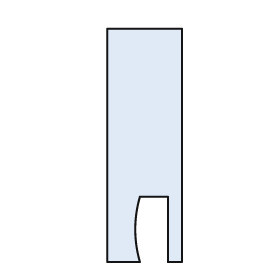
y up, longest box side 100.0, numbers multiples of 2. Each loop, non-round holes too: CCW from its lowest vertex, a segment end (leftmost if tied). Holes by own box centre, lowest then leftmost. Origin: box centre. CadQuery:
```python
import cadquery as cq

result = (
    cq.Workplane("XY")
    .moveTo(-16.0, -50.0)
    .lineTo(-2.0, -50.0)
    .threePointArc((-4.0, -36.0), (-2.0, -22.0))
    .lineTo(10.0, -22.0)
    .lineTo(10.0, -50.0)
    .lineTo(16.0, -50.0)
    .lineTo(16.0, 50.0)
    .lineTo(-16.0, 50.0)
    .close()
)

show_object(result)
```